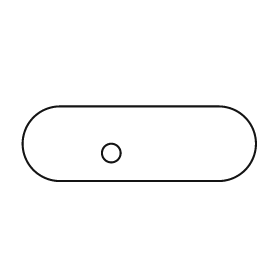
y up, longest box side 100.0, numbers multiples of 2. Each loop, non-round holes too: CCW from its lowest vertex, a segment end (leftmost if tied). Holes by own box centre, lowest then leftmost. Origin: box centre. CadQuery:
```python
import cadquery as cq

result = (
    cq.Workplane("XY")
    .moveTo(-34.0, -16.0)
    .lineTo(34.0, -16.0)
    .threePointArc((50.0, 0.0), (34.0, 16.0))
    .lineTo(-34.0, 16.0)
    .threePointArc((-50.0, 0.0), (-34.0, -16.0))
    .close()
    .moveTo(-12.0, -4.0)
    .circle(4.0)
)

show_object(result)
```